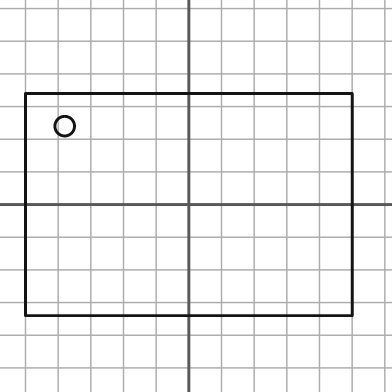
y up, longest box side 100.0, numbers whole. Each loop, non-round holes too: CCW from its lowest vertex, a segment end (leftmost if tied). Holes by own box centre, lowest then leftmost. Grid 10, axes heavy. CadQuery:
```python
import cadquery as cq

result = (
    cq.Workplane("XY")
    .moveTo(-50.0, -34.0)
    .lineTo(50.0, -34.0)
    .lineTo(50.0, 34.0)
    .lineTo(-50.0, 34.0)
    .close()
    .moveTo(-38.0, 24.0)
    .circle(3.0)
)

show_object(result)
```